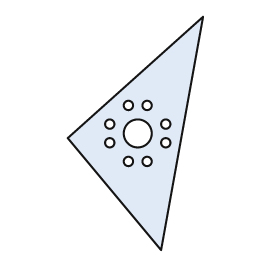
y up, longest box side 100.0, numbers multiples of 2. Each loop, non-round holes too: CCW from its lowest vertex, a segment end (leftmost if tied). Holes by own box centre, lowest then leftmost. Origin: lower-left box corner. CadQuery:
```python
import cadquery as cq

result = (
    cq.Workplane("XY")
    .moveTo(40.0, 0.0)
    .lineTo(58.0, 100.0)
    .lineTo(0.0, 48.0)
    .close()
    .moveTo(26.0, 38.0)
    .circle(2.0)
    .moveTo(34.0, 38.0)
    .circle(2.0)
    .moveTo(18.0, 46.0)
    .circle(2.0)
    .moveTo(42.0, 46.0)
    .circle(2.0)
    .moveTo(30.0, 50.0)
    .circle(6.0)
    .moveTo(18.0, 54.0)
    .circle(2.0)
    .moveTo(42.0, 54.0)
    .circle(2.0)
    .moveTo(26.0, 62.0)
    .circle(2.0)
    .moveTo(34.0, 62.0)
    .circle(2.0)
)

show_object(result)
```